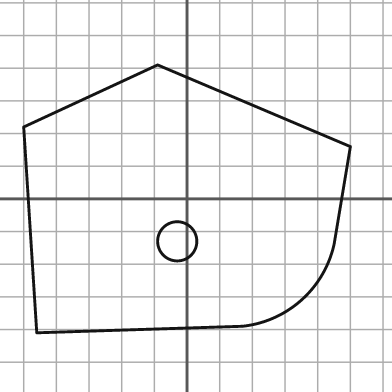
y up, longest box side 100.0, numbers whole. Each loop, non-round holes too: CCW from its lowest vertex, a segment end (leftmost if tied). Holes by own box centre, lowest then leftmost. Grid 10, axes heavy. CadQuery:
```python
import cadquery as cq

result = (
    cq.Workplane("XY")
    .moveTo(-46.0, -41.0)
    .lineTo(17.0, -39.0)
    .threePointArc((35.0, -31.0), (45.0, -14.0))
    .lineTo(50.0, 16.0)
    .lineTo(-9.0, 41.0)
    .lineTo(-50.0, 22.0)
    .close()
    .moveTo(-3.0, -13.0)
    .circle(6.0)
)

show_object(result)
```